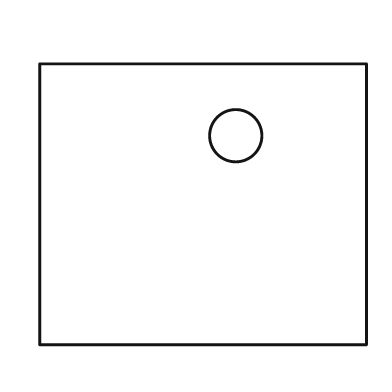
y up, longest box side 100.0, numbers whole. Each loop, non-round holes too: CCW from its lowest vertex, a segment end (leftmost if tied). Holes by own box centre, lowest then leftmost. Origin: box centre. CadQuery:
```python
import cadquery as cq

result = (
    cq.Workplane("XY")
    .moveTo(-50.0, -43.0)
    .lineTo(50.0, -43.0)
    .lineTo(50.0, 43.0)
    .lineTo(-50.0, 43.0)
    .close()
    .moveTo(10.0, 21.0)
    .circle(8.0)
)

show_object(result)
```